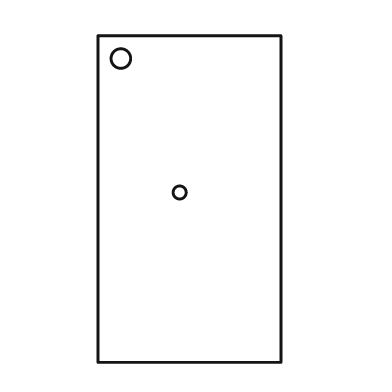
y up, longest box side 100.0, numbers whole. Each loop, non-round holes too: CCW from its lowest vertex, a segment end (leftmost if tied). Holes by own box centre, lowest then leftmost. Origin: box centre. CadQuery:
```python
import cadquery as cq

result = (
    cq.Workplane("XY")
    .moveTo(-28.0, -50.0)
    .lineTo(28.0, -50.0)
    .lineTo(28.0, 50.0)
    .lineTo(-28.0, 50.0)
    .close()
    .moveTo(-3.0, 2.0)
    .circle(2.0)
    .moveTo(-21.0, 43.0)
    .circle(3.0)
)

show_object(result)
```